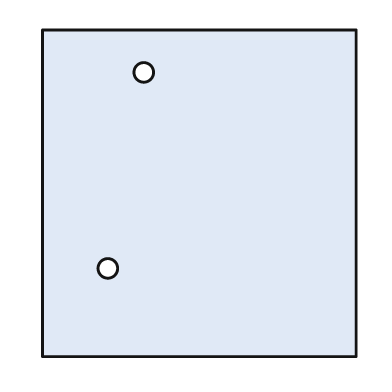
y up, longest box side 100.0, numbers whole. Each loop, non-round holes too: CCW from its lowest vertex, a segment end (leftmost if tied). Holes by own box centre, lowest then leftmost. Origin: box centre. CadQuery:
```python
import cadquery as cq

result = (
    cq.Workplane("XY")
    .moveTo(-48.0, -50.0)
    .lineTo(48.0, -50.0)
    .lineTo(48.0, 50.0)
    .lineTo(-48.0, 50.0)
    .close()
    .moveTo(-28.0, -23.0)
    .circle(3.0)
    .moveTo(-17.0, 37.0)
    .circle(3.0)
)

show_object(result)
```